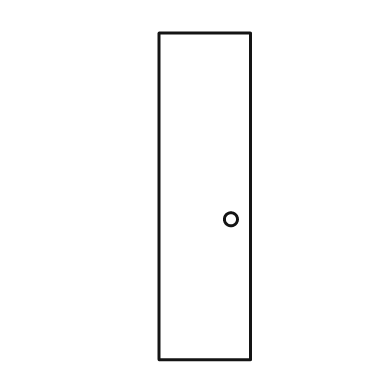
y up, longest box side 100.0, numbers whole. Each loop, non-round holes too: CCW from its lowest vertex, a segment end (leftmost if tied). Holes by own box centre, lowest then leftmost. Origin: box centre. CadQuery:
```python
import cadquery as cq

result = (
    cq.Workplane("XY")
    .moveTo(-14.0, -50.0)
    .lineTo(14.0, -50.0)
    .lineTo(14.0, 50.0)
    .lineTo(-14.0, 50.0)
    .close()
    .moveTo(8.0, -7.0)
    .circle(2.0)
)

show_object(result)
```